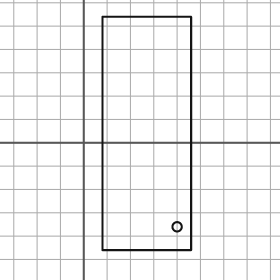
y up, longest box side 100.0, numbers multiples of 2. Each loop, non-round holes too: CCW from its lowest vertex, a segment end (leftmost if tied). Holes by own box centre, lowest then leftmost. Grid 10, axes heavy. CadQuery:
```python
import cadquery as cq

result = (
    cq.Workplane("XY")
    .moveTo(8.0, -46.0)
    .lineTo(46.0, -46.0)
    .lineTo(46.0, 54.0)
    .lineTo(8.0, 54.0)
    .close()
    .moveTo(40.0, -36.0)
    .circle(2.0)
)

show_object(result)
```